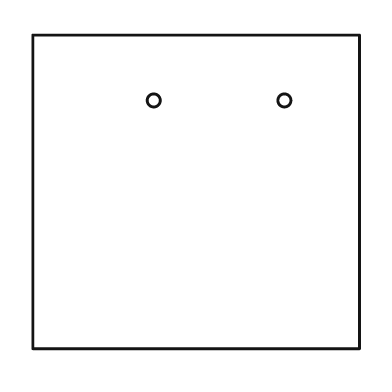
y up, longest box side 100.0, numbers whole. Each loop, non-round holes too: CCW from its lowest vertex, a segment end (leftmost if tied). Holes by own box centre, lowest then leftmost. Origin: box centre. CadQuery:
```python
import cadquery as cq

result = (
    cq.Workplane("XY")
    .moveTo(-50.0, -48.0)
    .lineTo(50.0, -48.0)
    .lineTo(50.0, 48.0)
    .lineTo(-50.0, 48.0)
    .close()
    .moveTo(-13.0, 28.0)
    .circle(2.0)
    .moveTo(27.0, 28.0)
    .circle(2.0)
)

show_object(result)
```